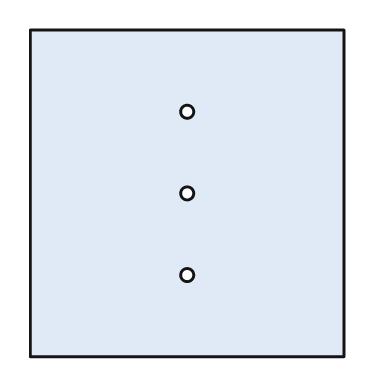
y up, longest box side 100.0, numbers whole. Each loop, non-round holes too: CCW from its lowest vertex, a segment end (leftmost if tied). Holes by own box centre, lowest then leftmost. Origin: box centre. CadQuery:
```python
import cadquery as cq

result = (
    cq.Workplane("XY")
    .moveTo(-48.0, -50.0)
    .lineTo(48.0, -50.0)
    .lineTo(48.0, 50.0)
    .lineTo(-48.0, 50.0)
    .close()
    .moveTo(0.0, -25.0)
    .circle(2.0)
    .moveTo(0.0, 0.0)
    .circle(2.0)
    .moveTo(0.0, 25.0)
    .circle(2.0)
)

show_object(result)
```